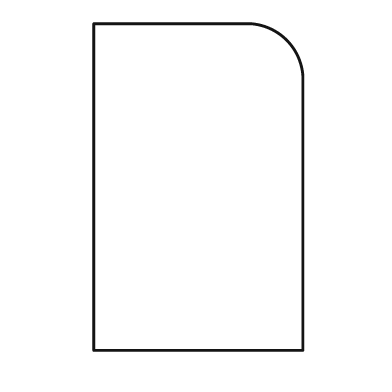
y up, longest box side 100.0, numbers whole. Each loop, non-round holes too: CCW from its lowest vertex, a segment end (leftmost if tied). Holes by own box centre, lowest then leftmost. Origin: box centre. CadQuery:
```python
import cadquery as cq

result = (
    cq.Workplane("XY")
    .moveTo(-32.0, -50.0)
    .lineTo(32.0, -50.0)
    .lineTo(32.0, 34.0)
    .threePointArc((27.0, 45.0), (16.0, 50.0))
    .lineTo(-32.0, 50.0)
    .close()
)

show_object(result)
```